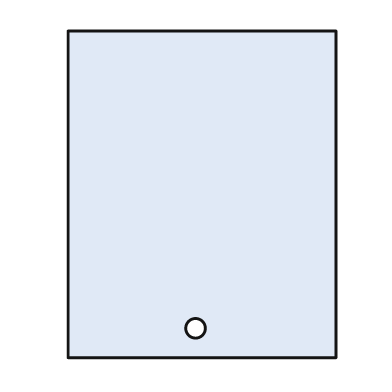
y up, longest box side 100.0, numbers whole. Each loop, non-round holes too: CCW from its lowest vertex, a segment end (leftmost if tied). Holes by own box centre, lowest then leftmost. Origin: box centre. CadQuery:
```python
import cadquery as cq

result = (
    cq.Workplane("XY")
    .moveTo(-41.0, -50.0)
    .lineTo(41.0, -50.0)
    .lineTo(41.0, 50.0)
    .lineTo(-41.0, 50.0)
    .close()
    .moveTo(-2.0, -41.0)
    .circle(3.0)
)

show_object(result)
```